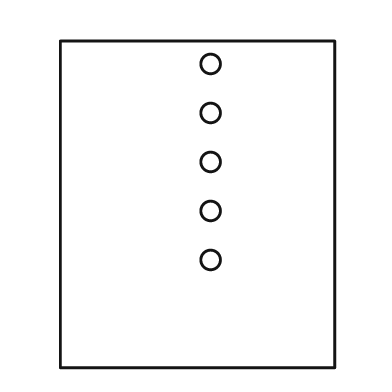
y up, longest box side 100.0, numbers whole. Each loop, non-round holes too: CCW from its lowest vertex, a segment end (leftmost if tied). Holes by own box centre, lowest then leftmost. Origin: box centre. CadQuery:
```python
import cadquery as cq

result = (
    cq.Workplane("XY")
    .moveTo(-42.0, -50.0)
    .lineTo(42.0, -50.0)
    .lineTo(42.0, 50.0)
    .lineTo(-42.0, 50.0)
    .close()
    .moveTo(4.0, -17.0)
    .circle(3.0)
    .moveTo(4.0, -2.0)
    .circle(3.0)
    .moveTo(4.0, 13.0)
    .circle(3.0)
    .moveTo(4.0, 28.0)
    .circle(3.0)
    .moveTo(4.0, 43.0)
    .circle(3.0)
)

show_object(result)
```